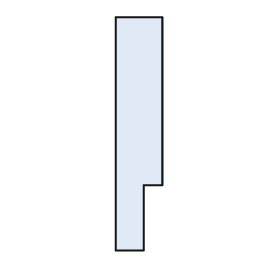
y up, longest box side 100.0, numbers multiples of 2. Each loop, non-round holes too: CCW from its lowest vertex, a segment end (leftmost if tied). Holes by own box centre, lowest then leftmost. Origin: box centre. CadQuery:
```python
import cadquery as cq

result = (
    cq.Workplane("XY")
    .moveTo(-10.0, -50.0)
    .lineTo(2.0, -50.0)
    .lineTo(2.0, -22.0)
    .lineTo(10.0, -22.0)
    .lineTo(10.0, 50.0)
    .lineTo(-10.0, 50.0)
    .close()
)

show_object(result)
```